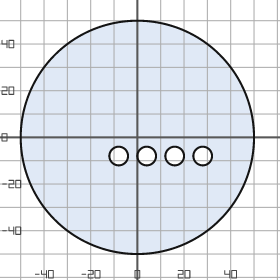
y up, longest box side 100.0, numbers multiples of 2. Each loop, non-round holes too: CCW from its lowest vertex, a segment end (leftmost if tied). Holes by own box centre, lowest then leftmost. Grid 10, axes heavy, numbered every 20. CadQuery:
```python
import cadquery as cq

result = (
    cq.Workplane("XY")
    .moveTo(0.0, 0.0)
    .circle(50.0)
    .moveTo(-8.0, -8.0)
    .circle(4.0)
    .moveTo(4.0, -8.0)
    .circle(4.0)
    .moveTo(16.0, -8.0)
    .circle(4.0)
    .moveTo(28.0, -8.0)
    .circle(4.0)
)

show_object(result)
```